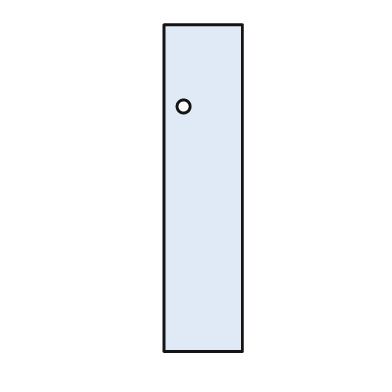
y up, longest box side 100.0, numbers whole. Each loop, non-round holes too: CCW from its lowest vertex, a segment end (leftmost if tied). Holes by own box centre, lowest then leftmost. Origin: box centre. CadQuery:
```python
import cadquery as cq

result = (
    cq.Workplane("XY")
    .moveTo(-12.0, -50.0)
    .lineTo(12.0, -50.0)
    .lineTo(12.0, 50.0)
    .lineTo(-12.0, 50.0)
    .close()
    .moveTo(-6.0, 25.0)
    .circle(2.0)
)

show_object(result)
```